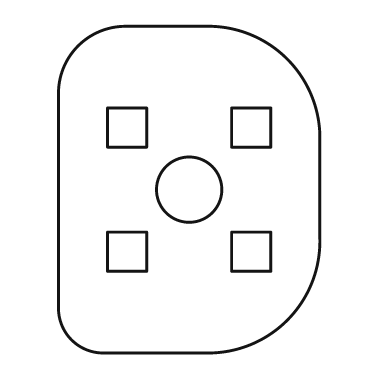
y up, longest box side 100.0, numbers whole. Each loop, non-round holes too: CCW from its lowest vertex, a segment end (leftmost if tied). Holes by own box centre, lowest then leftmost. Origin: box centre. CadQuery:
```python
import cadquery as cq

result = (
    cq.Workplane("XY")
    .moveTo(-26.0, -50.0)
    .lineTo(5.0, -50.0)
    .threePointArc((30.0, -40.0), (40.0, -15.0))
    .lineTo(40.0, 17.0)
    .threePointArc((30.0, 40.0), (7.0, 50.0))
    .lineTo(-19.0, 50.0)
    .threePointArc((-34.0, 44.0), (-40.0, 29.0))
    .lineTo(-40.0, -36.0)
    .threePointArc((-36.0, -46.0), (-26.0, -50.0))
    .close()
    .moveTo(-25.0, -25.0)
    .lineTo(-13.0, -25.0)
    .lineTo(-13.0, -13.0)
    .lineTo(-25.0, -13.0)
    .close()
    .moveTo(13.0, -25.0)
    .lineTo(25.0, -25.0)
    .lineTo(25.0, -13.0)
    .lineTo(13.0, -13.0)
    .close()
    .moveTo(0.0, 0.0)
    .circle(10.0)
    .moveTo(-25.0, 13.0)
    .lineTo(-13.0, 13.0)
    .lineTo(-13.0, 25.0)
    .lineTo(-25.0, 25.0)
    .close()
    .moveTo(13.0, 13.0)
    .lineTo(25.0, 13.0)
    .lineTo(25.0, 25.0)
    .lineTo(13.0, 25.0)
    .close()
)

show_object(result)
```